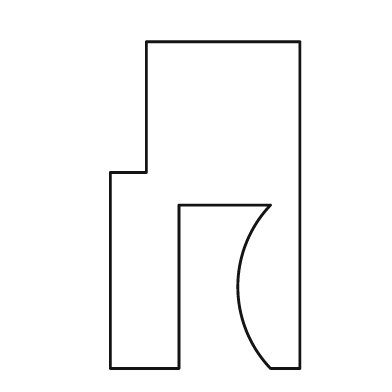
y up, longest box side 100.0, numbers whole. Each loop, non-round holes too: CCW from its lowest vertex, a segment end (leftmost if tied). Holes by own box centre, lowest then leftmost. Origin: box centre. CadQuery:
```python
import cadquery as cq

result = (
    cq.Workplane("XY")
    .moveTo(-29.0, -50.0)
    .lineTo(-8.0, -50.0)
    .lineTo(-8.0, 0.0)
    .lineTo(20.0, 0.0)
    .threePointArc((10.0, -25.0), (20.0, -50.0))
    .lineTo(29.0, -50.0)
    .lineTo(29.0, 50.0)
    .lineTo(-18.0, 50.0)
    .lineTo(-18.0, 10.0)
    .lineTo(-29.0, 10.0)
    .close()
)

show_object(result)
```